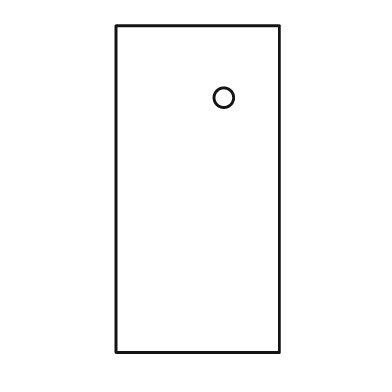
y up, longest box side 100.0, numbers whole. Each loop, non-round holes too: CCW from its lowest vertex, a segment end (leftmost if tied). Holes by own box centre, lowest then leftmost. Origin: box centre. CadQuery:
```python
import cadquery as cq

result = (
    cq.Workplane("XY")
    .moveTo(-25.0, -50.0)
    .lineTo(25.0, -50.0)
    .lineTo(25.0, 50.0)
    .lineTo(-25.0, 50.0)
    .close()
    .moveTo(8.0, 28.0)
    .circle(3.0)
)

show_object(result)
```